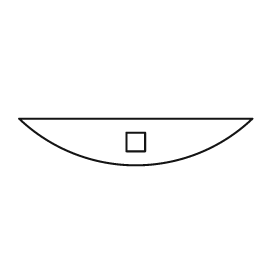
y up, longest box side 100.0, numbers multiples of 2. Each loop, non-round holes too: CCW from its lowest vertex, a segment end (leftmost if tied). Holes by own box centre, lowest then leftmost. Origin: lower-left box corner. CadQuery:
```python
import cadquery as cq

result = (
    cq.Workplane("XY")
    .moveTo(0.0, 20.0)
    .threePointArc((50.0, 0.0), (100.0, 20.0))
    .close()
    .moveTo(46.0, 6.0)
    .lineTo(54.0, 6.0)
    .lineTo(54.0, 14.0)
    .lineTo(46.0, 14.0)
    .close()
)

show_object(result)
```